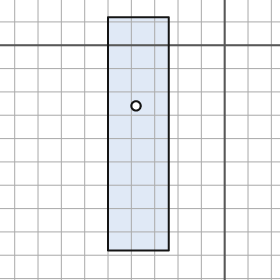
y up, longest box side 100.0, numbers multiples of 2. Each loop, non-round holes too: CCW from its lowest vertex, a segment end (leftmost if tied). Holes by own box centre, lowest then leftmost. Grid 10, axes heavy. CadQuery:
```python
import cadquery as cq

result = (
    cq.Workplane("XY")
    .moveTo(-50.0, -88.0)
    .lineTo(-24.0, -88.0)
    .lineTo(-24.0, 12.0)
    .lineTo(-50.0, 12.0)
    .close()
    .moveTo(-38.0, -26.0)
    .circle(2.0)
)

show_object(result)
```